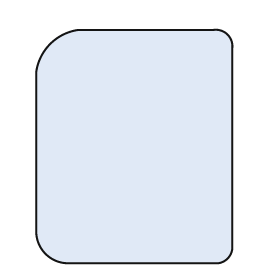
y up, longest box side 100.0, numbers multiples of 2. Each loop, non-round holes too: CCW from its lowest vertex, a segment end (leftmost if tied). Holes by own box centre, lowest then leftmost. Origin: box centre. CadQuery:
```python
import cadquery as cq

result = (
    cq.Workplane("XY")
    .moveTo(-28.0, -50.0)
    .lineTo(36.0, -50.0)
    .threePointArc((40.0, -48.0), (42.0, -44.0))
    .lineTo(42.0, 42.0)
    .threePointArc((40.0, 48.0), (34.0, 50.0))
    .lineTo(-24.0, 50.0)
    .threePointArc((-36.0, 44.0), (-42.0, 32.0))
    .lineTo(-42.0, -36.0)
    .threePointArc((-38.0, -46.0), (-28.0, -50.0))
    .close()
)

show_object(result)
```